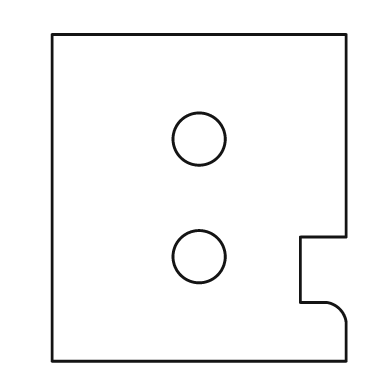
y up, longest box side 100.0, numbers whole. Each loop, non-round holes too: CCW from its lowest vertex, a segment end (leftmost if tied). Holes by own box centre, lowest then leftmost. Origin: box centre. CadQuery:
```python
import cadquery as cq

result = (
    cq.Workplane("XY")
    .moveTo(-45.0, -50.0)
    .lineTo(45.0, -50.0)
    .lineTo(45.0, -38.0)
    .threePointArc((43.0, -34.0), (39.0, -32.0))
    .lineTo(31.0, -32.0)
    .lineTo(31.0, -12.0)
    .lineTo(45.0, -12.0)
    .lineTo(45.0, 50.0)
    .lineTo(-45.0, 50.0)
    .close()
    .moveTo(0.0, -18.0)
    .circle(8.0)
    .moveTo(0.0, 18.0)
    .circle(8.0)
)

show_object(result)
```